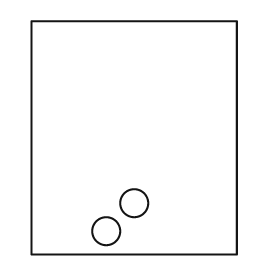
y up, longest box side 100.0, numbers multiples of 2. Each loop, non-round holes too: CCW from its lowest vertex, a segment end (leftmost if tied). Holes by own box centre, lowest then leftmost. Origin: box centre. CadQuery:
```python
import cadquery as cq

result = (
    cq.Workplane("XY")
    .moveTo(-44.0, -50.0)
    .lineTo(44.0, -50.0)
    .lineTo(44.0, 50.0)
    .lineTo(-44.0, 50.0)
    .close()
    .moveTo(-12.0, -40.0)
    .circle(6.0)
    .moveTo(0.0, -28.0)
    .circle(6.0)
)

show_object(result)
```